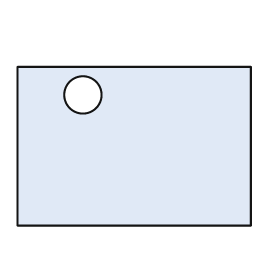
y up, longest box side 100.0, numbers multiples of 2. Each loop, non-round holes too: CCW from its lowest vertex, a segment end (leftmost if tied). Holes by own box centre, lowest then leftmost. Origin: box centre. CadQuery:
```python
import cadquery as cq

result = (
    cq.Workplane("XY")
    .moveTo(-50.0, -34.0)
    .lineTo(50.0, -34.0)
    .lineTo(50.0, 34.0)
    .lineTo(-50.0, 34.0)
    .close()
    .moveTo(-22.0, 22.0)
    .circle(8.0)
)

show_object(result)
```